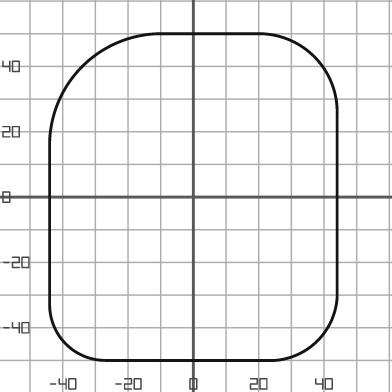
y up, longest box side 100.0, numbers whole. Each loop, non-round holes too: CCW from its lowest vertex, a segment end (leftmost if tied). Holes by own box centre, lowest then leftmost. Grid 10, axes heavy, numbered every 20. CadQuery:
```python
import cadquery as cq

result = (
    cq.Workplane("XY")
    .moveTo(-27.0, -50.0)
    .lineTo(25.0, -50.0)
    .threePointArc((38.0, -44.0), (44.0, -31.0))
    .lineTo(44.0, 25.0)
    .threePointArc((37.0, 43.0), (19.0, 50.0))
    .lineTo(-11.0, 50.0)
    .threePointArc((-34.0, 40.0), (-44.0, 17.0))
    .lineTo(-44.0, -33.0)
    .threePointArc((-39.0, -45.0), (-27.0, -50.0))
    .close()
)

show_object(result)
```